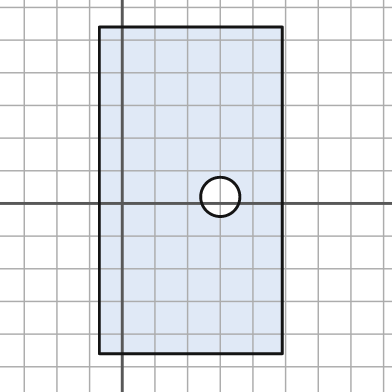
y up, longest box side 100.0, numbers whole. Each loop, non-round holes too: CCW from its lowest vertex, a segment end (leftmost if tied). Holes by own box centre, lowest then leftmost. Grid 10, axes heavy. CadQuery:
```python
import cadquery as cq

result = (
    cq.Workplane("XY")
    .moveTo(-7.0, -46.0)
    .lineTo(49.0, -46.0)
    .lineTo(49.0, 54.0)
    .lineTo(-7.0, 54.0)
    .close()
    .moveTo(30.0, 2.0)
    .circle(6.0)
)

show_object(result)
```